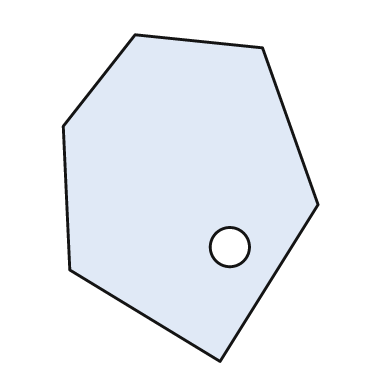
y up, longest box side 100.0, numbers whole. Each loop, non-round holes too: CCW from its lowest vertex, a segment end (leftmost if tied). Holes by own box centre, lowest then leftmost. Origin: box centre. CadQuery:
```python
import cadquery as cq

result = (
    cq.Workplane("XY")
    .moveTo(9.0, -50.0)
    .lineTo(39.0, -2.0)
    .lineTo(22.0, 46.0)
    .lineTo(-17.0, 50.0)
    .lineTo(-39.0, 22.0)
    .lineTo(-37.0, -22.0)
    .close()
    .moveTo(12.0, -15.0)
    .circle(6.0)
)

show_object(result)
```